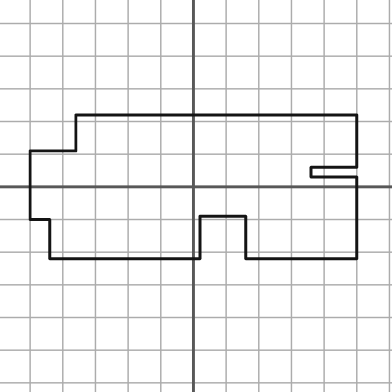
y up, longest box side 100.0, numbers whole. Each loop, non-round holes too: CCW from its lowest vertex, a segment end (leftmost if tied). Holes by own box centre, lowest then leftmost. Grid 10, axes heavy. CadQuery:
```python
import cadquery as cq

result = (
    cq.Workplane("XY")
    .moveTo(-44.0, -22.0)
    .lineTo(2.0, -22.0)
    .lineTo(2.0, -9.0)
    .lineTo(16.0, -9.0)
    .lineTo(16.0, -22.0)
    .lineTo(50.0, -22.0)
    .lineTo(50.0, 3.0)
    .lineTo(36.0, 3.0)
    .lineTo(36.0, 6.0)
    .lineTo(50.0, 6.0)
    .lineTo(50.0, 22.0)
    .lineTo(-36.0, 22.0)
    .lineTo(-36.0, 11.0)
    .lineTo(-50.0, 11.0)
    .lineTo(-50.0, -10.0)
    .lineTo(-44.0, -10.0)
    .close()
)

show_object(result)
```